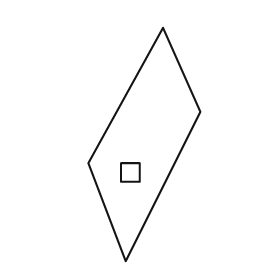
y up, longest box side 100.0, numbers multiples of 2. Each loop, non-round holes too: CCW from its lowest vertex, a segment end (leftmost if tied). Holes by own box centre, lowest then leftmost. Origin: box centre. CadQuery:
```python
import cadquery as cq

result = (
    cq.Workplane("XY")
    .moveTo(-8.0, -50.0)
    .lineTo(24.0, 14.0)
    .lineTo(8.0, 50.0)
    .lineTo(-24.0, -8.0)
    .close()
    .moveTo(-10.0, -16.0)
    .lineTo(-2.0, -16.0)
    .lineTo(-2.0, -8.0)
    .lineTo(-10.0, -8.0)
    .close()
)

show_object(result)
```